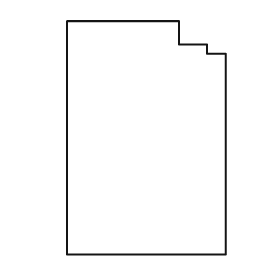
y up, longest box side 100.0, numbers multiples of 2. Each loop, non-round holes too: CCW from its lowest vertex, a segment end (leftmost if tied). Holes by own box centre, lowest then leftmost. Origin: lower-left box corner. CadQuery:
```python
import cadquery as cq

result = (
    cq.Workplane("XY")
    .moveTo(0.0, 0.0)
    .lineTo(68.0, 0.0)
    .lineTo(68.0, 86.0)
    .lineTo(60.0, 86.0)
    .lineTo(60.0, 90.0)
    .lineTo(48.0, 90.0)
    .lineTo(48.0, 100.0)
    .lineTo(0.0, 100.0)
    .close()
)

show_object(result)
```